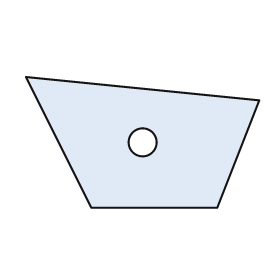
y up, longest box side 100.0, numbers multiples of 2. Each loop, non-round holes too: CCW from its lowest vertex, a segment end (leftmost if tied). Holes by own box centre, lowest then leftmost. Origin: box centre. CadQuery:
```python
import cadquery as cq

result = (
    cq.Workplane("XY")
    .moveTo(-22.0, -28.0)
    .lineTo(32.0, -28.0)
    .lineTo(50.0, 18.0)
    .lineTo(-50.0, 28.0)
    .close()
    .moveTo(0.0, 0.0)
    .circle(6.0)
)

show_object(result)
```